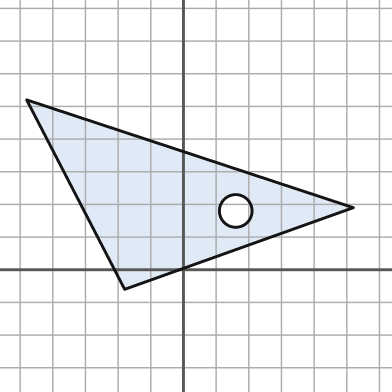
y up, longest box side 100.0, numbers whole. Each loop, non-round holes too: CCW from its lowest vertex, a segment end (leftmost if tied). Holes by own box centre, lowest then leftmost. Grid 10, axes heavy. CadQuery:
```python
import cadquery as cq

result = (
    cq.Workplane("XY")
    .moveTo(-18.0, -6.0)
    .lineTo(52.0, 19.0)
    .lineTo(-48.0, 52.0)
    .close()
    .moveTo(16.0, 18.0)
    .circle(5.0)
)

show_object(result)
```